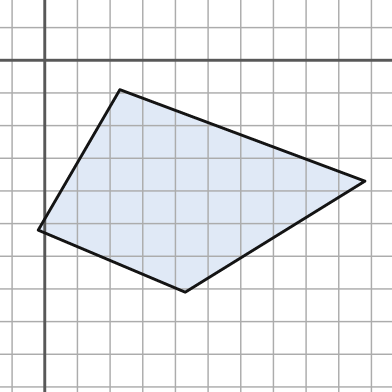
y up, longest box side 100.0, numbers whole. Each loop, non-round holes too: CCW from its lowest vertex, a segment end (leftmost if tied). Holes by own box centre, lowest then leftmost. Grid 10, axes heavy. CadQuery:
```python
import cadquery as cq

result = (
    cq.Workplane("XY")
    .moveTo(43.0, -71.0)
    .lineTo(98.0, -37.0)
    .lineTo(23.0, -9.0)
    .lineTo(-2.0, -52.0)
    .close()
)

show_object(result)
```